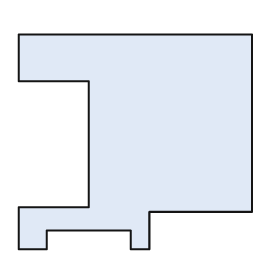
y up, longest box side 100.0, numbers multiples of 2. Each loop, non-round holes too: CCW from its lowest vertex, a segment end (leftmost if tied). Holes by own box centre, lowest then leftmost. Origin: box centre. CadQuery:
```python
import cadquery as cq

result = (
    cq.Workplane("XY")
    .moveTo(-50.0, -46.0)
    .lineTo(-38.0, -46.0)
    .lineTo(-38.0, -38.0)
    .lineTo(-2.0, -38.0)
    .lineTo(-2.0, -46.0)
    .lineTo(6.0, -46.0)
    .lineTo(6.0, -30.0)
    .lineTo(50.0, -30.0)
    .lineTo(50.0, 46.0)
    .lineTo(-50.0, 46.0)
    .lineTo(-50.0, 26.0)
    .lineTo(-20.0, 26.0)
    .lineTo(-20.0, -28.0)
    .lineTo(-50.0, -28.0)
    .close()
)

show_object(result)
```